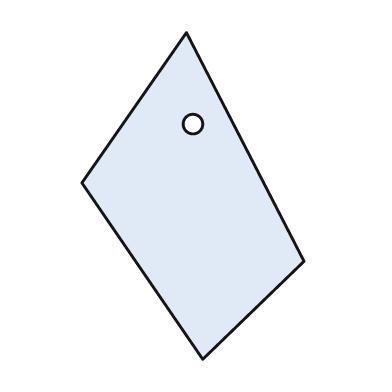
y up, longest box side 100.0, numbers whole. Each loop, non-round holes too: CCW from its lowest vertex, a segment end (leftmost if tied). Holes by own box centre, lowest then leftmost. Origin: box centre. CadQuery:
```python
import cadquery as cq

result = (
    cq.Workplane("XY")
    .moveTo(3.0, -50.0)
    .lineTo(34.0, -20.0)
    .lineTo(-2.0, 50.0)
    .lineTo(-34.0, 4.0)
    .close()
    .moveTo(0.0, 22.0)
    .circle(3.0)
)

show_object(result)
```